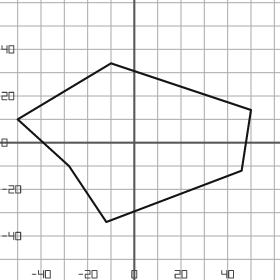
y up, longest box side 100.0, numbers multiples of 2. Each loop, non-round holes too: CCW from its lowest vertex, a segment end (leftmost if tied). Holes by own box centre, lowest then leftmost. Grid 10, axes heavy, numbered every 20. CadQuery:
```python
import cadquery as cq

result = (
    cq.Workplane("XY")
    .moveTo(-12.0, -34.0)
    .lineTo(46.0, -12.0)
    .lineTo(50.0, 14.0)
    .lineTo(-10.0, 34.0)
    .lineTo(-50.0, 10.0)
    .lineTo(-28.0, -10.0)
    .close()
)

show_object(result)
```